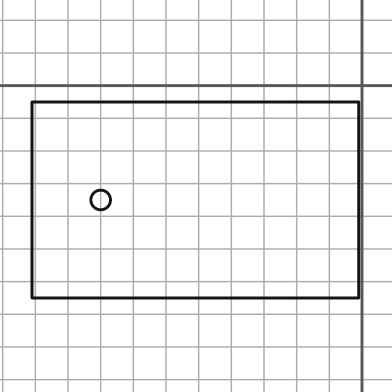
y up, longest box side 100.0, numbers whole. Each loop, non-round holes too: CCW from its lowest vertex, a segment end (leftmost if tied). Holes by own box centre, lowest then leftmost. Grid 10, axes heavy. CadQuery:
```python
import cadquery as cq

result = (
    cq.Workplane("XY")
    .moveTo(-101.0, -65.0)
    .lineTo(-1.0, -65.0)
    .lineTo(-1.0, -5.0)
    .lineTo(-101.0, -5.0)
    .close()
    .moveTo(-80.0, -35.0)
    .circle(3.0)
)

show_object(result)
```